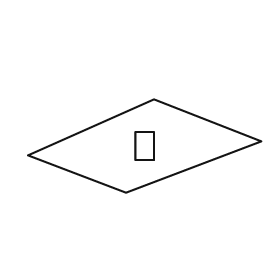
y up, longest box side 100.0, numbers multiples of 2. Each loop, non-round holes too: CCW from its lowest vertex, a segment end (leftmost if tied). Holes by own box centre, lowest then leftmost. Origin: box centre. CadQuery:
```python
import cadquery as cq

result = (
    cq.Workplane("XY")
    .moveTo(-8.0, -20.0)
    .lineTo(50.0, 2.0)
    .lineTo(4.0, 20.0)
    .lineTo(-50.0, -4.0)
    .close()
    .moveTo(-4.0, -6.0)
    .lineTo(4.0, -6.0)
    .lineTo(4.0, 6.0)
    .lineTo(-4.0, 6.0)
    .close()
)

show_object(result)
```